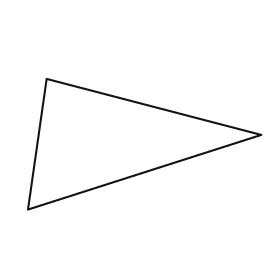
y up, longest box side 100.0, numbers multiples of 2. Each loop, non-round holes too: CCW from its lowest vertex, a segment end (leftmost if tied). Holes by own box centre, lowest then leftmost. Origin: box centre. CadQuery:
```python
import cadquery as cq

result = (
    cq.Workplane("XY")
    .moveTo(-50.0, -28.0)
    .lineTo(50.0, 4.0)
    .lineTo(-42.0, 28.0)
    .close()
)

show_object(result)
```